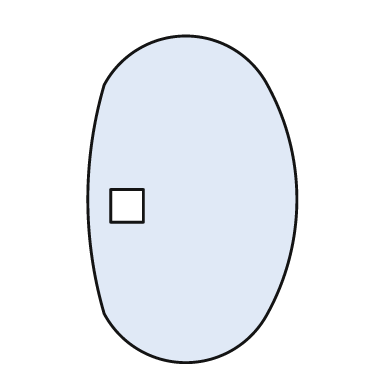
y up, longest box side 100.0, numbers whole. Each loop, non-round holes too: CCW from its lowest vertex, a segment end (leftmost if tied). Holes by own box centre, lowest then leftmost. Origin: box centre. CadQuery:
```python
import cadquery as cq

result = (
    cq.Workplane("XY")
    .moveTo(-27.0, -35.0)
    .threePointArc((-2.0, -50.0), (23.0, -35.0))
    .threePointArc((32.0, 0.0), (23.0, 35.0))
    .threePointArc((-2.0, 50.0), (-27.0, 35.0))
    .threePointArc((-32.0, 0.0), (-27.0, -35.0))
    .close()
    .moveTo(-25.0, -7.0)
    .lineTo(-15.0, -7.0)
    .lineTo(-15.0, 3.0)
    .lineTo(-25.0, 3.0)
    .close()
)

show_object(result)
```